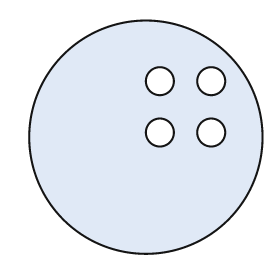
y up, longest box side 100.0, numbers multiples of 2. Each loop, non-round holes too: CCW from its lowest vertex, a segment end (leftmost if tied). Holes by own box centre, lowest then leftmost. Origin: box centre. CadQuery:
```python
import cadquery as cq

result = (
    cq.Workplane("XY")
    .moveTo(0.0, 0.0)
    .circle(50.0)
    .moveTo(6.0, 2.0)
    .circle(6.0)
    .moveTo(28.0, 2.0)
    .circle(6.0)
    .moveTo(6.0, 24.0)
    .circle(6.0)
    .moveTo(28.0, 24.0)
    .circle(6.0)
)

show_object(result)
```